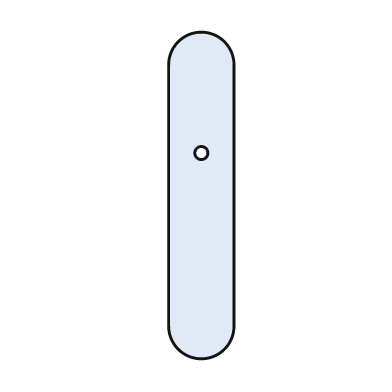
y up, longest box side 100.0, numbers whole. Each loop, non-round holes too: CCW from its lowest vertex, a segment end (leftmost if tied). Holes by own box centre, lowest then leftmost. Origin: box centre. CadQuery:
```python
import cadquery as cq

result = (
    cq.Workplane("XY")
    .moveTo(-10.0, -40.0)
    .threePointArc((0.0, -50.0), (10.0, -40.0))
    .lineTo(10.0, 40.0)
    .threePointArc((0.0, 50.0), (-10.0, 40.0))
    .close()
    .moveTo(0.0, 13.0)
    .circle(2.0)
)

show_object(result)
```